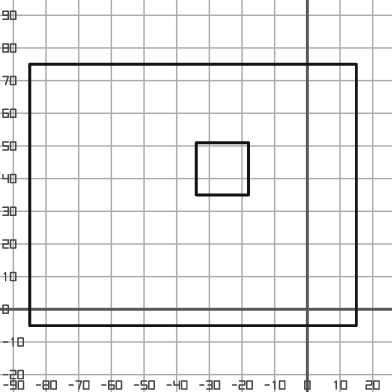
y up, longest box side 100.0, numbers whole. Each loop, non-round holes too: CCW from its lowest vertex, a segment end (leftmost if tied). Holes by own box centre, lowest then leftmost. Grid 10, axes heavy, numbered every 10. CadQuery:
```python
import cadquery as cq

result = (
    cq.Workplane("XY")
    .moveTo(-85.0, -5.0)
    .lineTo(15.0, -5.0)
    .lineTo(15.0, 75.0)
    .lineTo(-85.0, 75.0)
    .close()
    .moveTo(-34.0, 35.0)
    .lineTo(-18.0, 35.0)
    .lineTo(-18.0, 51.0)
    .lineTo(-34.0, 51.0)
    .close()
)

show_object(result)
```